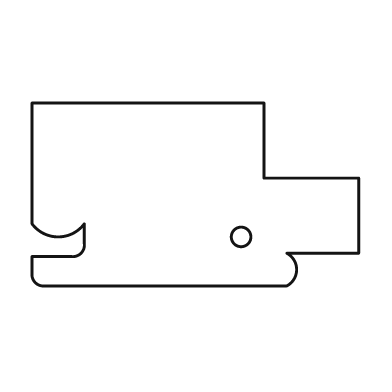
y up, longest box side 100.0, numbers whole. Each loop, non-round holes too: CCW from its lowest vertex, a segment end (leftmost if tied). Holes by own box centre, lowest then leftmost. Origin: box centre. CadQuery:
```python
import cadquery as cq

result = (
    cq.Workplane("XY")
    .moveTo(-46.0, -28.0)
    .lineTo(28.0, -28.0)
    .threePointArc((31.0, -23.0), (28.0, -18.0))
    .lineTo(50.0, -18.0)
    .lineTo(50.0, 5.0)
    .lineTo(21.0, 5.0)
    .lineTo(21.0, 28.0)
    .lineTo(-50.0, 28.0)
    .lineTo(-50.0, -9.0)
    .threePointArc((-42.0, -13.0), (-34.0, -9.0))
    .lineTo(-34.0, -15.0)
    .threePointArc((-35.0, -18.0), (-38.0, -19.0))
    .lineTo(-50.0, -19.0)
    .lineTo(-50.0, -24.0)
    .threePointArc((-49.0, -27.0), (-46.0, -28.0))
    .close()
    .moveTo(14.0, -13.0)
    .circle(3.0)
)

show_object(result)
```